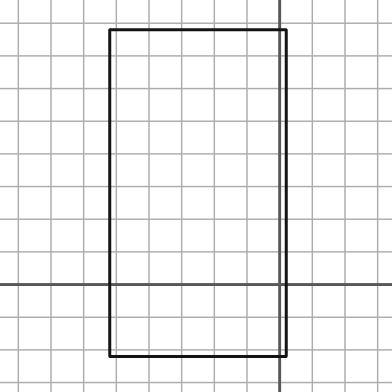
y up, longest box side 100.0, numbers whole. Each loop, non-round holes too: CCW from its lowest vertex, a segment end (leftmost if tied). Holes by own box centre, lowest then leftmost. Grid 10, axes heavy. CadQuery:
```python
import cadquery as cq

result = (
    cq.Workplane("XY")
    .moveTo(-52.0, -22.0)
    .lineTo(2.0, -22.0)
    .lineTo(2.0, 78.0)
    .lineTo(-52.0, 78.0)
    .close()
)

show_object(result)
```